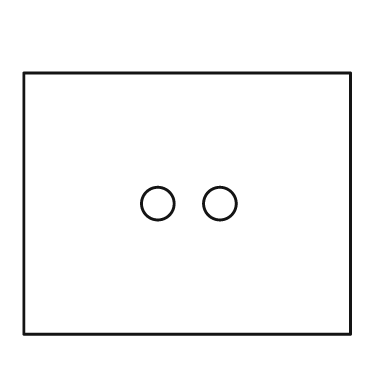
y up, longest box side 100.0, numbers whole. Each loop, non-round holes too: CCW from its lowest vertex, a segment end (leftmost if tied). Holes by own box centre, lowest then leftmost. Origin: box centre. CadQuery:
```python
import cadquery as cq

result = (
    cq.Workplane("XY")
    .moveTo(-50.0, -40.0)
    .lineTo(50.0, -40.0)
    .lineTo(50.0, 40.0)
    .lineTo(-50.0, 40.0)
    .close()
    .moveTo(-9.0, 0.0)
    .circle(5.0)
    .moveTo(10.0, 0.0)
    .circle(5.0)
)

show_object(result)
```